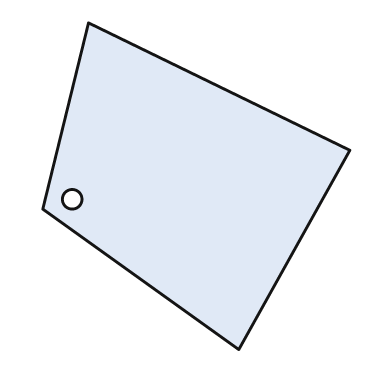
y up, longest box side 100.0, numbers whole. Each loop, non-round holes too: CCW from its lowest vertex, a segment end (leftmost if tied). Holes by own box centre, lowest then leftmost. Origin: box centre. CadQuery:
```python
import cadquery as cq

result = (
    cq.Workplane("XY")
    .moveTo(13.0, -50.0)
    .lineTo(47.0, 11.0)
    .lineTo(-33.0, 50.0)
    .lineTo(-47.0, -7.0)
    .close()
    .moveTo(-38.0, -4.0)
    .circle(3.0)
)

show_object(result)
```